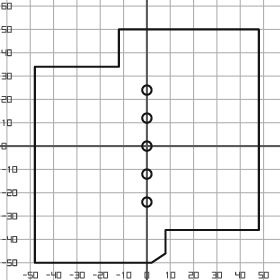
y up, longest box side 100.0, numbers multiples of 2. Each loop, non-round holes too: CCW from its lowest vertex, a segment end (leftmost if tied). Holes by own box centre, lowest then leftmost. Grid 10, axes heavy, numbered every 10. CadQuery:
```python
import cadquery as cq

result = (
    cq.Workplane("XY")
    .moveTo(-48.0, -50.0)
    .lineTo(2.0, -50.0)
    .lineTo(8.0, -46.0)
    .lineTo(8.0, -36.0)
    .lineTo(48.0, -36.0)
    .lineTo(48.0, 50.0)
    .lineTo(-12.0, 50.0)
    .lineTo(-12.0, 34.0)
    .lineTo(-48.0, 34.0)
    .close()
    .moveTo(0.0, -24.0)
    .circle(2.0)
    .moveTo(0.0, -12.0)
    .circle(2.0)
    .moveTo(0.0, 0.0)
    .circle(2.0)
    .moveTo(0.0, 12.0)
    .circle(2.0)
    .moveTo(0.0, 24.0)
    .circle(2.0)
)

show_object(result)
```